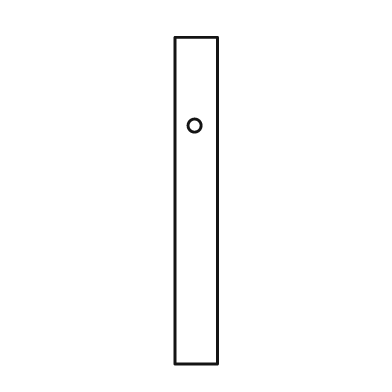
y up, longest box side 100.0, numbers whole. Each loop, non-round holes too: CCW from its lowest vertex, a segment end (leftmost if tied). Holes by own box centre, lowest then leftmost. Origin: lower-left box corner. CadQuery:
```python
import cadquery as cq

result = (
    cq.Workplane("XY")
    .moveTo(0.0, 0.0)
    .lineTo(13.0, 0.0)
    .lineTo(13.0, 100.0)
    .lineTo(0.0, 100.0)
    .close()
    .moveTo(6.0, 73.0)
    .circle(2.0)
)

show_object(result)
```